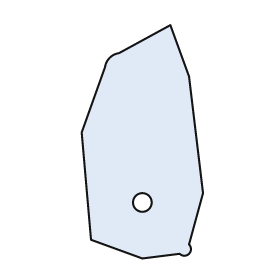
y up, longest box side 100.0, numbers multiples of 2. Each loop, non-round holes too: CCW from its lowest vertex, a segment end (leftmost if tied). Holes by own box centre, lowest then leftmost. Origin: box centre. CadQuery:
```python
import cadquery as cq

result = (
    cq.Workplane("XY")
    .moveTo(0.0, -50.0)
    .lineTo(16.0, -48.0)
    .threePointArc((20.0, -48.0), (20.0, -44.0))
    .lineTo(26.0, -22.0)
    .lineTo(20.0, 28.0)
    .lineTo(12.0, 50.0)
    .lineTo(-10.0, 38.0)
    .threePointArc((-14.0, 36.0), (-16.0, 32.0))
    .lineTo(-26.0, 4.0)
    .lineTo(-22.0, -42.0)
    .close()
    .moveTo(0.0, -26.0)
    .circle(4.0)
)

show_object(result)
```